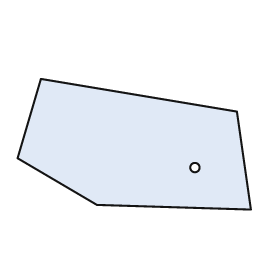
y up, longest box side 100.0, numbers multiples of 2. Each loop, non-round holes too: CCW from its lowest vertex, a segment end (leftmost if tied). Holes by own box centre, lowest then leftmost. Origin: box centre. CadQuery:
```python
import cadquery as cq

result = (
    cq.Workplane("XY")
    .moveTo(50.0, -28.0)
    .lineTo(44.0, 14.0)
    .lineTo(-40.0, 28.0)
    .lineTo(-50.0, -6.0)
    .lineTo(-16.0, -26.0)
    .close()
    .moveTo(26.0, -10.0)
    .circle(2.0)
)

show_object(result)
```